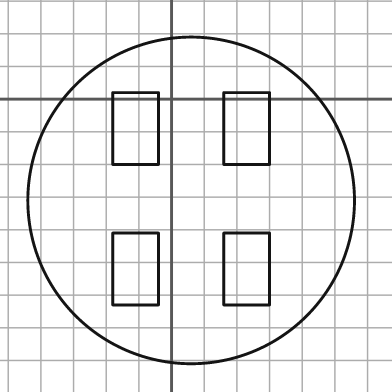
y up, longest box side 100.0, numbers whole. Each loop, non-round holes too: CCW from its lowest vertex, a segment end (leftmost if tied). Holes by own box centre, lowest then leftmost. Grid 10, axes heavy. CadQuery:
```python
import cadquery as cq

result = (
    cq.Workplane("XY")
    .moveTo(6.0, -31.0)
    .circle(50.0)
    .moveTo(-18.0, -63.0)
    .lineTo(-4.0, -63.0)
    .lineTo(-4.0, -41.0)
    .lineTo(-18.0, -41.0)
    .close()
    .moveTo(16.0, -63.0)
    .lineTo(30.0, -63.0)
    .lineTo(30.0, -41.0)
    .lineTo(16.0, -41.0)
    .close()
    .moveTo(-18.0, -20.0)
    .lineTo(-4.0, -20.0)
    .lineTo(-4.0, 2.0)
    .lineTo(-18.0, 2.0)
    .close()
    .moveTo(16.0, -20.0)
    .lineTo(30.0, -20.0)
    .lineTo(30.0, 2.0)
    .lineTo(16.0, 2.0)
    .close()
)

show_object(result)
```